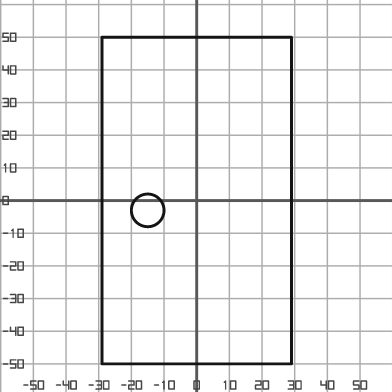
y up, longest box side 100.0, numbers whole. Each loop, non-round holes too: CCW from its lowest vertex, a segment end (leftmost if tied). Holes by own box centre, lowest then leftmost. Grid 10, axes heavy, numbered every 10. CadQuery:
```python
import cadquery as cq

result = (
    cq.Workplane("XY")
    .moveTo(-29.0, -50.0)
    .lineTo(29.0, -50.0)
    .lineTo(29.0, 50.0)
    .lineTo(-29.0, 50.0)
    .close()
    .moveTo(-15.0, -3.0)
    .circle(5.0)
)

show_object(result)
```